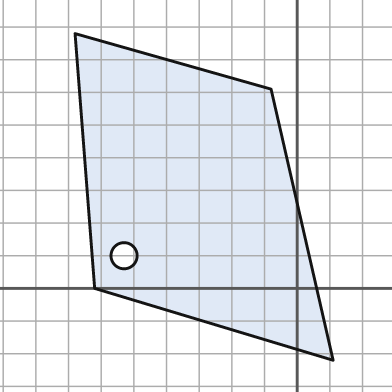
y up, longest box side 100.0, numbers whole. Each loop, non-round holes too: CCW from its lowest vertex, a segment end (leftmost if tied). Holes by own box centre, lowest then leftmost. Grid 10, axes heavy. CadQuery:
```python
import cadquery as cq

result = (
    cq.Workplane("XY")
    .moveTo(11.0, -22.0)
    .lineTo(-8.0, 61.0)
    .lineTo(-68.0, 78.0)
    .lineTo(-62.0, 0.0)
    .close()
    .moveTo(-53.0, 10.0)
    .circle(4.0)
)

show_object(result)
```